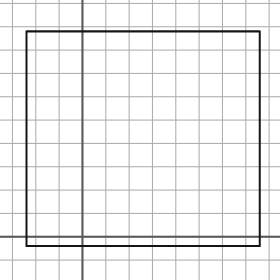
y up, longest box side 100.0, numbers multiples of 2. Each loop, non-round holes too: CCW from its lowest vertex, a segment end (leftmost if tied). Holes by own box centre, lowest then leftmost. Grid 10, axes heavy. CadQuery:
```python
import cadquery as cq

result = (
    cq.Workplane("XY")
    .moveTo(-24.0, -4.0)
    .lineTo(76.0, -4.0)
    .lineTo(76.0, 88.0)
    .lineTo(-24.0, 88.0)
    .close()
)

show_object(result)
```